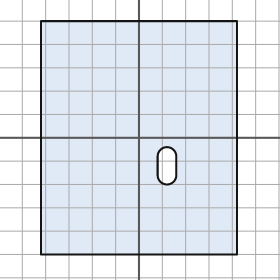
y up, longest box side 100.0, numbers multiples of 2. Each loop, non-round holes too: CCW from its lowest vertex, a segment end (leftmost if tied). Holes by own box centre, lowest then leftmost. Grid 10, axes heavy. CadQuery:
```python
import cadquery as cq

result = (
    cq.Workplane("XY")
    .moveTo(-42.0, -50.0)
    .lineTo(42.0, -50.0)
    .lineTo(42.0, 50.0)
    .lineTo(-42.0, 50.0)
    .close()
    .moveTo(8.0, -16.0)
    .threePointArc((12.0, -20.0), (16.0, -16.0))
    .lineTo(16.0, -8.0)
    .threePointArc((12.0, -4.0), (8.0, -8.0))
    .close()
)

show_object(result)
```